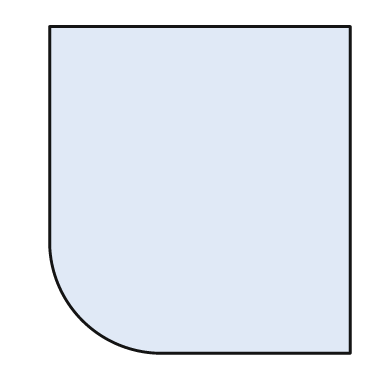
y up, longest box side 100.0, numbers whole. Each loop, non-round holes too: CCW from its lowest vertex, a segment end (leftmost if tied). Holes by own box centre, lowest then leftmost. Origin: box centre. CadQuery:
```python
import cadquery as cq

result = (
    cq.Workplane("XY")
    .moveTo(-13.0, -50.0)
    .lineTo(46.0, -50.0)
    .lineTo(46.0, 50.0)
    .lineTo(-46.0, 50.0)
    .lineTo(-46.0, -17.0)
    .threePointArc((-36.0, -40.0), (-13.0, -50.0))
    .close()
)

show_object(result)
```